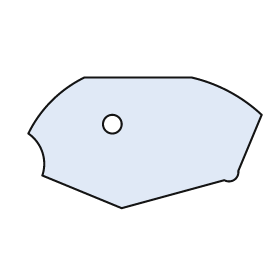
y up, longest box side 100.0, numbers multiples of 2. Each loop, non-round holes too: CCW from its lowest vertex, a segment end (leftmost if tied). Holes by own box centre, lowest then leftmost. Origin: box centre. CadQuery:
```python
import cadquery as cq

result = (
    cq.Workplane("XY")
    .moveTo(-10.0, -28.0)
    .lineTo(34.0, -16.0)
    .threePointArc((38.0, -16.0), (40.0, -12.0))
    .lineTo(50.0, 12.0)
    .threePointArc((36.0, 22.0), (20.0, 28.0))
    .lineTo(-26.0, 28.0)
    .threePointArc((-40.0, 18.0), (-50.0, 4.0))
    .threePointArc((-44.0, -4.0), (-44.0, -14.0))
    .close()
    .moveTo(-14.0, 8.0)
    .circle(4.0)
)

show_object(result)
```